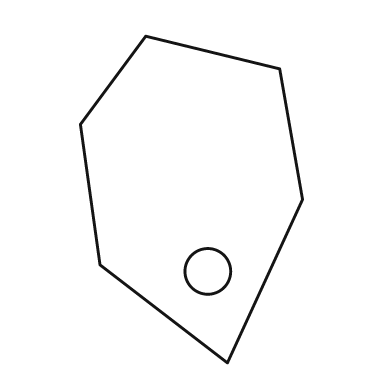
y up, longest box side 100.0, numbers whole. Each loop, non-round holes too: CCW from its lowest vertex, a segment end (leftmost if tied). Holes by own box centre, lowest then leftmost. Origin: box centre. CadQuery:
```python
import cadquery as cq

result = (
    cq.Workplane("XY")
    .moveTo(11.0, -50.0)
    .lineTo(34.0, 0.0)
    .lineTo(27.0, 40.0)
    .lineTo(-14.0, 50.0)
    .lineTo(-34.0, 23.0)
    .lineTo(-28.0, -20.0)
    .close()
    .moveTo(5.0, -22.0)
    .circle(7.0)
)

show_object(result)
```